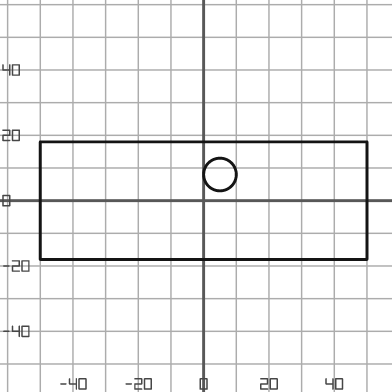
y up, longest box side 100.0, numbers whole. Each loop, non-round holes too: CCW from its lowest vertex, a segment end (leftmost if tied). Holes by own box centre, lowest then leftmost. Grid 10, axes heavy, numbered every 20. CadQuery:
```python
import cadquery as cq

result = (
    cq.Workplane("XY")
    .moveTo(-50.0, -18.0)
    .lineTo(50.0, -18.0)
    .lineTo(50.0, 18.0)
    .lineTo(-50.0, 18.0)
    .close()
    .moveTo(5.0, 8.0)
    .circle(5.0)
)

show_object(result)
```